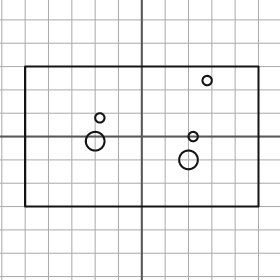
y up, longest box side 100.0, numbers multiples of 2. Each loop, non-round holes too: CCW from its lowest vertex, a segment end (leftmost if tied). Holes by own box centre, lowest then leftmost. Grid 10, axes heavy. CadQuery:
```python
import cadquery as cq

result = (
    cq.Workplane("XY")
    .moveTo(-50.0, -30.0)
    .lineTo(50.0, -30.0)
    .lineTo(50.0, 30.0)
    .lineTo(-50.0, 30.0)
    .close()
    .moveTo(20.0, -10.0)
    .circle(4.0)
    .moveTo(-20.0, -2.0)
    .circle(4.0)
    .moveTo(22.0, 0.0)
    .circle(2.0)
    .moveTo(-18.0, 8.0)
    .circle(2.0)
    .moveTo(28.0, 24.0)
    .circle(2.0)
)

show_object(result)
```